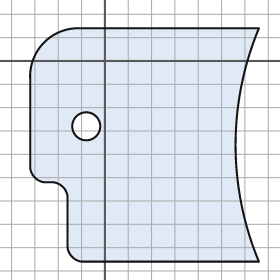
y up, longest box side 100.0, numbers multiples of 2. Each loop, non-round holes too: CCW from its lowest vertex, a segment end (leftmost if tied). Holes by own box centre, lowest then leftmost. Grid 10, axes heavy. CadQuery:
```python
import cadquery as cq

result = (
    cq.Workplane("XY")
    .moveTo(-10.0, -86.0)
    .lineTo(66.0, -86.0)
    .threePointArc((56.0, -36.0), (66.0, 14.0))
    .lineTo(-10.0, 14.0)
    .threePointArc((-26.0, 8.0), (-32.0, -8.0))
    .lineTo(-32.0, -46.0)
    .threePointArc((-30.0, -50.0), (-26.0, -52.0))
    .lineTo(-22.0, -52.0)
    .threePointArc((-18.0, -54.0), (-16.0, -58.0))
    .lineTo(-16.0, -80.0)
    .threePointArc((-14.0, -84.0), (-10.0, -86.0))
    .close()
    .moveTo(-8.0, -28.0)
    .circle(6.0)
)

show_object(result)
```